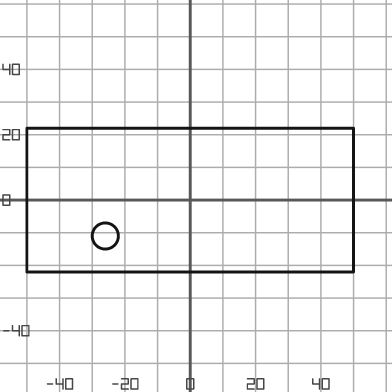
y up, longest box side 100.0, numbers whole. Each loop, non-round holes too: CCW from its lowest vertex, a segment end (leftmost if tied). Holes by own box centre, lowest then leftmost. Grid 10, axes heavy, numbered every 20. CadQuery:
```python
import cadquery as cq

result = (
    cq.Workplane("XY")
    .moveTo(-50.0, -22.0)
    .lineTo(50.0, -22.0)
    .lineTo(50.0, 22.0)
    .lineTo(-50.0, 22.0)
    .close()
    .moveTo(-26.0, -11.0)
    .circle(4.0)
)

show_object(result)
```